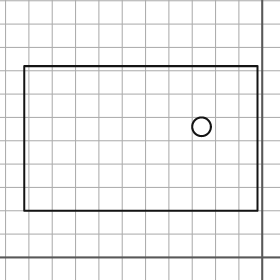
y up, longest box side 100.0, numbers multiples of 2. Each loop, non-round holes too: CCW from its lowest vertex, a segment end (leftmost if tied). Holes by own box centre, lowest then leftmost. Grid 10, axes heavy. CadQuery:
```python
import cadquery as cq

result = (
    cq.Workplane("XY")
    .moveTo(-102.0, 20.0)
    .lineTo(-2.0, 20.0)
    .lineTo(-2.0, 82.0)
    .lineTo(-102.0, 82.0)
    .close()
    .moveTo(-26.0, 56.0)
    .circle(4.0)
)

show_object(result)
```